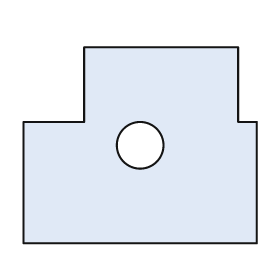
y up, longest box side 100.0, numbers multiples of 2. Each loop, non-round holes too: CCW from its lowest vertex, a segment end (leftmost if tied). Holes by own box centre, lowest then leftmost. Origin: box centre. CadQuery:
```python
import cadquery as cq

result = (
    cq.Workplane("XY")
    .moveTo(-50.0, -42.0)
    .lineTo(50.0, -42.0)
    .lineTo(50.0, 10.0)
    .lineTo(42.0, 10.0)
    .lineTo(42.0, 42.0)
    .lineTo(-24.0, 42.0)
    .lineTo(-24.0, 10.0)
    .lineTo(-50.0, 10.0)
    .close()
    .moveTo(0.0, 0.0)
    .circle(10.0)
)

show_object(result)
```